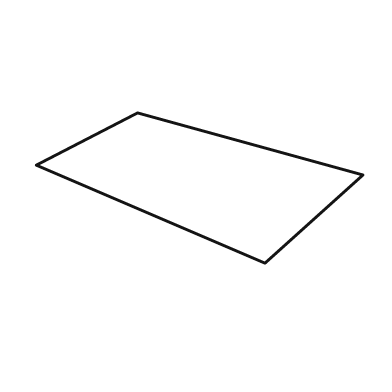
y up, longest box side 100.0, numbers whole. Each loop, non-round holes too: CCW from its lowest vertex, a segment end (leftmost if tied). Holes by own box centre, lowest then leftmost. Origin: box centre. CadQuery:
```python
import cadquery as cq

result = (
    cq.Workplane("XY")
    .moveTo(20.0, -23.0)
    .lineTo(50.0, 4.0)
    .lineTo(-19.0, 23.0)
    .lineTo(-50.0, 7.0)
    .close()
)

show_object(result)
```